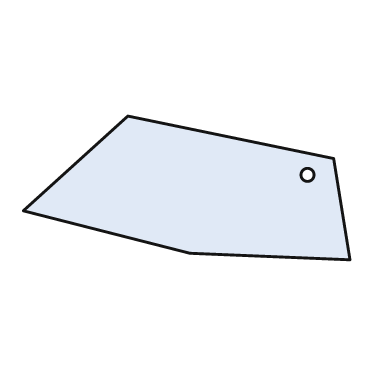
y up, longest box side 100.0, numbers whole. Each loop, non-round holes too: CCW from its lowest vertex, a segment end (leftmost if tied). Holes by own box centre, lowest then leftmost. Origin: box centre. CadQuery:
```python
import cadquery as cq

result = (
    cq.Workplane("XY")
    .moveTo(50.0, -22.0)
    .lineTo(45.0, 9.0)
    .lineTo(-18.0, 22.0)
    .lineTo(-50.0, -7.0)
    .lineTo(1.0, -20.0)
    .close()
    .moveTo(37.0, 4.0)
    .circle(2.0)
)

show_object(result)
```